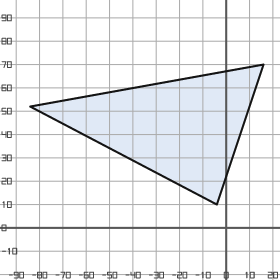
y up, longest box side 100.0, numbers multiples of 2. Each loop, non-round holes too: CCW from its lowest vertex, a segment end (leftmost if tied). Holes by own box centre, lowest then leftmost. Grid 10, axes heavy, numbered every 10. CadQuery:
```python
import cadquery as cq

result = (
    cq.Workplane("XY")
    .moveTo(-4.0, 10.0)
    .lineTo(16.0, 70.0)
    .lineTo(-84.0, 52.0)
    .close()
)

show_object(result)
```